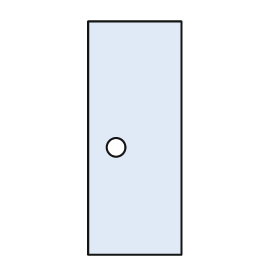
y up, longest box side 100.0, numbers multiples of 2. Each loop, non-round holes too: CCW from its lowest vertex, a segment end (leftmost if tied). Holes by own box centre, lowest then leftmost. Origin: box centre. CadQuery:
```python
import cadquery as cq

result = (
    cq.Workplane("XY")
    .moveTo(-20.0, -50.0)
    .lineTo(20.0, -50.0)
    .lineTo(20.0, 50.0)
    .lineTo(-20.0, 50.0)
    .close()
    .moveTo(-8.0, -4.0)
    .circle(4.0)
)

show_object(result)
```